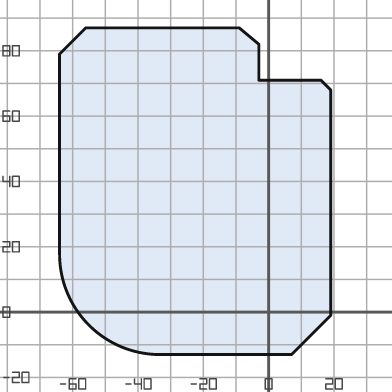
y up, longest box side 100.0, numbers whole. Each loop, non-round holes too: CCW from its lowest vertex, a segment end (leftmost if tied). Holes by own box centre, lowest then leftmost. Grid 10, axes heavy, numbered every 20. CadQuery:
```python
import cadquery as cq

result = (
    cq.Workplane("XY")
    .moveTo(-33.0, -13.0)
    .lineTo(7.0, -13.0)
    .lineTo(19.0, -1.0)
    .lineTo(19.0, 68.0)
    .lineTo(16.0, 71.0)
    .lineTo(-3.0, 71.0)
    .lineTo(-3.0, 82.0)
    .lineTo(-9.0, 87.0)
    .lineTo(-56.0, 87.0)
    .lineTo(-64.0, 79.0)
    .lineTo(-64.0, 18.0)
    .threePointArc((-55.0, -4.0), (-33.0, -13.0))
    .close()
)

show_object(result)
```